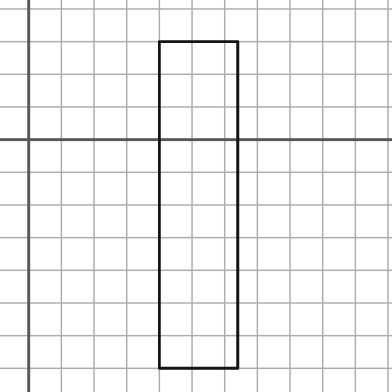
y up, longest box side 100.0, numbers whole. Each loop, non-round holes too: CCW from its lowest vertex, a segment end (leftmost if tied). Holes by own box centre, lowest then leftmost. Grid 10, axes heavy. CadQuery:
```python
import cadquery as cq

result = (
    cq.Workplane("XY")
    .moveTo(40.0, -70.0)
    .lineTo(64.0, -70.0)
    .lineTo(64.0, 30.0)
    .lineTo(40.0, 30.0)
    .close()
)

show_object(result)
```